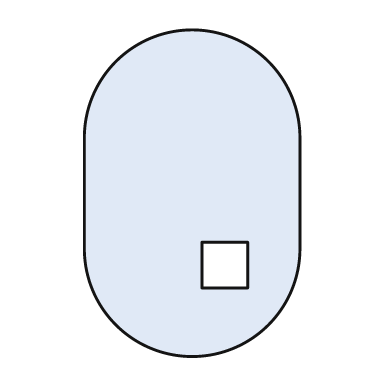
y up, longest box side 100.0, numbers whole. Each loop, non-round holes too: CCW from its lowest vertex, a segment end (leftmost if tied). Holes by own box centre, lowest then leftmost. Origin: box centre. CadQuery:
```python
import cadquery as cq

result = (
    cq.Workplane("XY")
    .moveTo(-33.0, -17.0)
    .threePointArc((0.0, -50.0), (33.0, -17.0))
    .lineTo(33.0, 17.0)
    .threePointArc((0.0, 50.0), (-33.0, 17.0))
    .close()
    .moveTo(3.0, -29.0)
    .lineTo(17.0, -29.0)
    .lineTo(17.0, -15.0)
    .lineTo(3.0, -15.0)
    .close()
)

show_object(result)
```